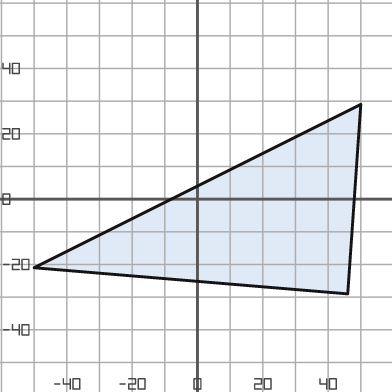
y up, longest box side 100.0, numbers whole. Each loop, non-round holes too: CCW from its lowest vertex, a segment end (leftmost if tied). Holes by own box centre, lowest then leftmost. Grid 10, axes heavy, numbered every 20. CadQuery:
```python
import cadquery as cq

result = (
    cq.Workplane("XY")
    .moveTo(46.0, -29.0)
    .lineTo(50.0, 29.0)
    .lineTo(-50.0, -21.0)
    .close()
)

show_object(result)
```